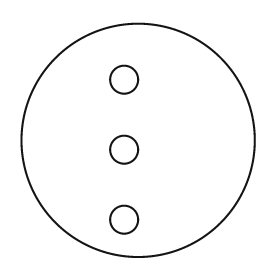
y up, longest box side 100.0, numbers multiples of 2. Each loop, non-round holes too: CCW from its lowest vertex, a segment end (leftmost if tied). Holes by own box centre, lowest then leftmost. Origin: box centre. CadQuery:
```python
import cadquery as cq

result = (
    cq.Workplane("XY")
    .moveTo(0.0, 0.0)
    .circle(50.0)
    .moveTo(-6.0, -34.0)
    .circle(6.0)
    .moveTo(-6.0, -4.0)
    .circle(6.0)
    .moveTo(-6.0, 26.0)
    .circle(6.0)
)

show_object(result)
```